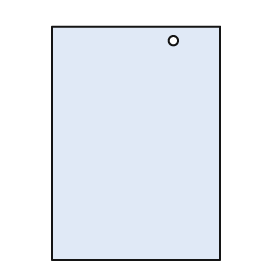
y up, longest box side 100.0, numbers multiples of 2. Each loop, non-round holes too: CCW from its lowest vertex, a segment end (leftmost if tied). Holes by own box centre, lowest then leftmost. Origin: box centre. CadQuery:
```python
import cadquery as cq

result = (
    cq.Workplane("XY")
    .moveTo(-36.0, -50.0)
    .lineTo(36.0, -50.0)
    .lineTo(36.0, 50.0)
    .lineTo(-36.0, 50.0)
    .close()
    .moveTo(16.0, 44.0)
    .circle(2.0)
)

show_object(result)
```